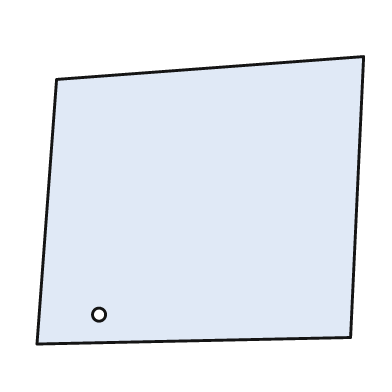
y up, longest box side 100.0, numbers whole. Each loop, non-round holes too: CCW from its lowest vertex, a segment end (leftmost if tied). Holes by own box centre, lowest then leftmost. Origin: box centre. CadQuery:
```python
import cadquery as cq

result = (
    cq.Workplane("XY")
    .moveTo(-50.0, -44.0)
    .lineTo(46.0, -42.0)
    .lineTo(50.0, 44.0)
    .lineTo(-44.0, 37.0)
    .close()
    .moveTo(-31.0, -35.0)
    .circle(2.0)
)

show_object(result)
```